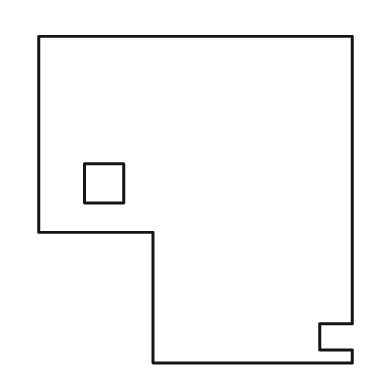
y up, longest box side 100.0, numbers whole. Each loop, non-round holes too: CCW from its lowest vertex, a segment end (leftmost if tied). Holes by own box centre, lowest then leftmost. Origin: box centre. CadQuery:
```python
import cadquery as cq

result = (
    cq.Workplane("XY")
    .moveTo(-13.0, -50.0)
    .lineTo(48.0, -50.0)
    .lineTo(48.0, -46.0)
    .lineTo(38.0, -46.0)
    .lineTo(38.0, -38.0)
    .lineTo(48.0, -38.0)
    .lineTo(48.0, 50.0)
    .lineTo(-48.0, 50.0)
    .lineTo(-48.0, -10.0)
    .lineTo(-13.0, -10.0)
    .close()
    .moveTo(-34.0, -1.0)
    .lineTo(-22.0, -1.0)
    .lineTo(-22.0, 11.0)
    .lineTo(-34.0, 11.0)
    .close()
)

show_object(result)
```